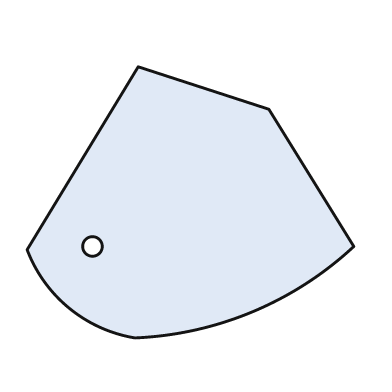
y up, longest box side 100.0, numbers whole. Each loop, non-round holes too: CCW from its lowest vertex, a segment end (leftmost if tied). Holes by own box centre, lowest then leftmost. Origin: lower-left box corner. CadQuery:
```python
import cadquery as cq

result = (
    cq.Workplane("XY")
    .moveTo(33.0, 0.0)
    .threePointArc((69.0, 8.0), (100.0, 28.0))
    .lineTo(74.0, 70.0)
    .lineTo(34.0, 83.0)
    .lineTo(0.0, 27.0)
    .threePointArc((13.0, 9.0), (33.0, 0.0))
    .close()
    .moveTo(20.0, 28.0)
    .circle(3.0)
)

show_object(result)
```